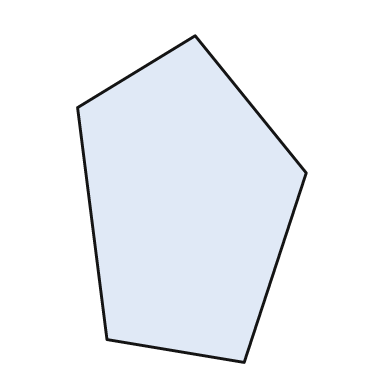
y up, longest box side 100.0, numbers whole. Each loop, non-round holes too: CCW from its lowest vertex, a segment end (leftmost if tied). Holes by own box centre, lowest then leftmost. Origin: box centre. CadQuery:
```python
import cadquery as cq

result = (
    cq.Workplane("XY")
    .moveTo(16.0, -50.0)
    .lineTo(35.0, 8.0)
    .lineTo(1.0, 50.0)
    .lineTo(-35.0, 28.0)
    .lineTo(-26.0, -43.0)
    .close()
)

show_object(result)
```